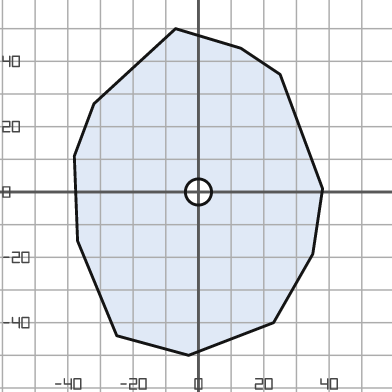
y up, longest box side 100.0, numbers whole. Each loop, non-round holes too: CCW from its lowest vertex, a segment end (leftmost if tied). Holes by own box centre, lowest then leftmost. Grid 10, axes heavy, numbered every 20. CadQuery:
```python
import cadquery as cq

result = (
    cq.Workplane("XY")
    .moveTo(-3.0, -50.0)
    .lineTo(23.0, -40.0)
    .lineTo(35.0, -19.0)
    .lineTo(38.0, 1.0)
    .lineTo(25.0, 36.0)
    .lineTo(13.0, 44.0)
    .lineTo(-7.0, 50.0)
    .lineTo(-32.0, 27.0)
    .lineTo(-38.0, 11.0)
    .lineTo(-37.0, -15.0)
    .lineTo(-25.0, -44.0)
    .close()
    .moveTo(0.0, 0.0)
    .circle(4.0)
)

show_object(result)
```